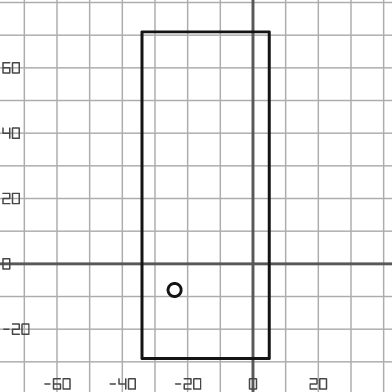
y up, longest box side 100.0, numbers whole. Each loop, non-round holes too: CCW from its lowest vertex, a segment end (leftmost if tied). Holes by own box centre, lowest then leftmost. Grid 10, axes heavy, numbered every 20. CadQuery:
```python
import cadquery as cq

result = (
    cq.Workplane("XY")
    .moveTo(-34.0, -29.0)
    .lineTo(5.0, -29.0)
    .lineTo(5.0, 71.0)
    .lineTo(-34.0, 71.0)
    .close()
    .moveTo(-24.0, -8.0)
    .circle(2.0)
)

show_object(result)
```